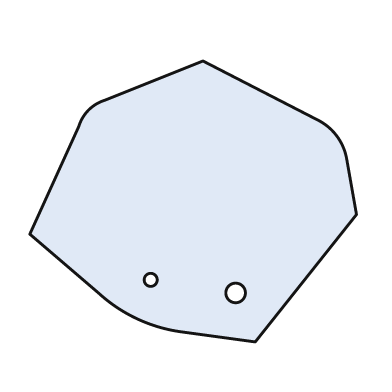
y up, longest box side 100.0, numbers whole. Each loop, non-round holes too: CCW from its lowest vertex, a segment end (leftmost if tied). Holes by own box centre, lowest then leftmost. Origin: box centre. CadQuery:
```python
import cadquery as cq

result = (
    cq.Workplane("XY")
    .moveTo(19.0, -43.0)
    .lineTo(50.0, -4.0)
    .lineTo(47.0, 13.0)
    .threePointArc((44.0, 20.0), (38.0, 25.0))
    .lineTo(3.0, 43.0)
    .lineTo(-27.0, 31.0)
    .threePointArc((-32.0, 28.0), (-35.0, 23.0))
    .lineTo(-50.0, -10.0)
    .lineTo(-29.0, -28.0)
    .threePointArc((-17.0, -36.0), (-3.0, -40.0))
    .close()
    .moveTo(13.0, -28.0)
    .circle(3.0)
    .moveTo(-13.0, -24.0)
    .circle(2.0)
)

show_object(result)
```